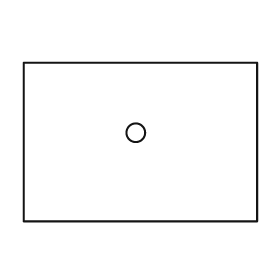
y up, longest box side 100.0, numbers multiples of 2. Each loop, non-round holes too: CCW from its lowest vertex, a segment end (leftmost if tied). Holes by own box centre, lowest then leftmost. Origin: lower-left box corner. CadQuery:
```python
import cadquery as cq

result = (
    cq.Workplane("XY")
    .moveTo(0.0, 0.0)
    .lineTo(100.0, 0.0)
    .lineTo(100.0, 68.0)
    .lineTo(0.0, 68.0)
    .close()
    .moveTo(48.0, 38.0)
    .circle(4.0)
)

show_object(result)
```